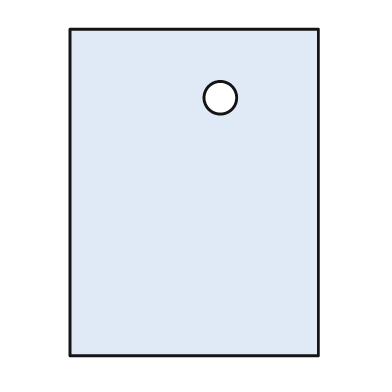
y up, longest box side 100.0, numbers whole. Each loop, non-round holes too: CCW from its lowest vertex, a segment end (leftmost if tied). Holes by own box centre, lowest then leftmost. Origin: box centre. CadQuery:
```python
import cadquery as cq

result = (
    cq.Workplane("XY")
    .moveTo(-38.0, -50.0)
    .lineTo(38.0, -50.0)
    .lineTo(38.0, 50.0)
    .lineTo(-38.0, 50.0)
    .close()
    .moveTo(8.0, 29.0)
    .circle(5.0)
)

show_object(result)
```